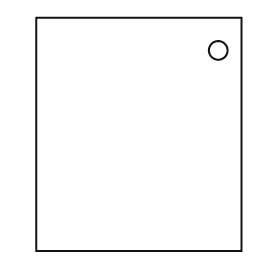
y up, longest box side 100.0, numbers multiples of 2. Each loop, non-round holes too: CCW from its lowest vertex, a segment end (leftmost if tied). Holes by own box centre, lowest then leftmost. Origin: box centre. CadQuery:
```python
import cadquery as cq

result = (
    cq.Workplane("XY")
    .moveTo(-44.0, -50.0)
    .lineTo(44.0, -50.0)
    .lineTo(44.0, 50.0)
    .lineTo(-44.0, 50.0)
    .close()
    .moveTo(34.0, 36.0)
    .circle(4.0)
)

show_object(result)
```